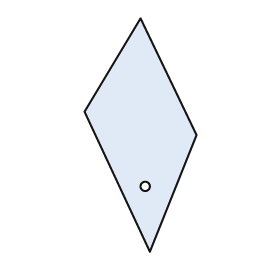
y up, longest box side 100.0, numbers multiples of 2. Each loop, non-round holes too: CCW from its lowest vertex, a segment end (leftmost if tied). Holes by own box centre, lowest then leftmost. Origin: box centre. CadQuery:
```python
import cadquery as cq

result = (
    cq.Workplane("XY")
    .moveTo(4.0, -50.0)
    .lineTo(24.0, 0.0)
    .lineTo(0.0, 50.0)
    .lineTo(-24.0, 10.0)
    .close()
    .moveTo(2.0, -22.0)
    .circle(2.0)
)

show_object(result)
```